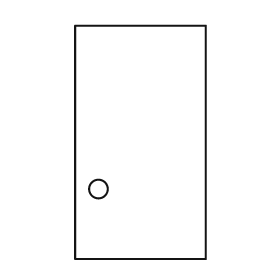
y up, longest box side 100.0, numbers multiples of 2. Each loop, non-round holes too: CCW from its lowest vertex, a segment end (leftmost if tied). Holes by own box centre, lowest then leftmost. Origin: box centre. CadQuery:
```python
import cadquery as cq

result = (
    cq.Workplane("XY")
    .moveTo(-28.0, -50.0)
    .lineTo(28.0, -50.0)
    .lineTo(28.0, 50.0)
    .lineTo(-28.0, 50.0)
    .close()
    .moveTo(-18.0, -20.0)
    .circle(4.0)
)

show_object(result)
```